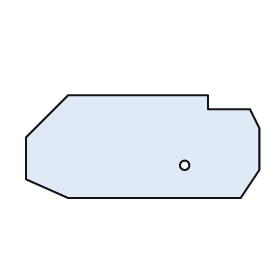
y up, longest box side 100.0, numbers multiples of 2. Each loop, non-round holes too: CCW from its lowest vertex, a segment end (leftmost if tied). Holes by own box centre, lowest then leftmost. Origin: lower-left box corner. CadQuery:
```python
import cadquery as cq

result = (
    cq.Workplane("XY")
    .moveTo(18.0, 0.0)
    .lineTo(92.0, 0.0)
    .lineTo(100.0, 12.0)
    .lineTo(100.0, 30.0)
    .lineTo(96.0, 38.0)
    .lineTo(78.0, 38.0)
    .lineTo(78.0, 44.0)
    .lineTo(18.0, 44.0)
    .lineTo(0.0, 26.0)
    .lineTo(0.0, 8.0)
    .close()
    .moveTo(68.0, 14.0)
    .circle(2.0)
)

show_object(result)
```